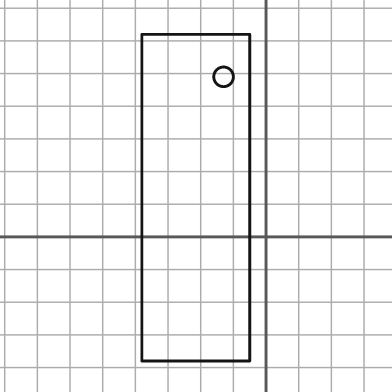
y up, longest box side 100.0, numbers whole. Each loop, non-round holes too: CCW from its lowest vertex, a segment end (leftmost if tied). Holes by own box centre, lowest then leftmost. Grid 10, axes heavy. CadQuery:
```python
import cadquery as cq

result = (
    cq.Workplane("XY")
    .moveTo(-38.0, -38.0)
    .lineTo(-5.0, -38.0)
    .lineTo(-5.0, 62.0)
    .lineTo(-38.0, 62.0)
    .close()
    .moveTo(-13.0, 49.0)
    .circle(3.0)
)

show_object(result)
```